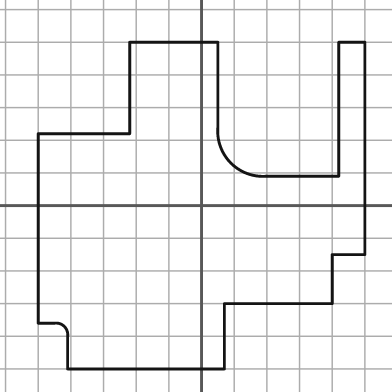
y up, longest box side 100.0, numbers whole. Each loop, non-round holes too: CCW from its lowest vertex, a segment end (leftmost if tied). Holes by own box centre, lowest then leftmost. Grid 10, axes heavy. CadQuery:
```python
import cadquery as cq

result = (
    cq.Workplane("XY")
    .moveTo(-41.0, -50.0)
    .lineTo(7.0, -50.0)
    .lineTo(7.0, -30.0)
    .lineTo(40.0, -30.0)
    .lineTo(40.0, -15.0)
    .lineTo(50.0, -15.0)
    .lineTo(50.0, 50.0)
    .lineTo(42.0, 50.0)
    .lineTo(42.0, 9.0)
    .lineTo(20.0, 9.0)
    .threePointArc((9.0, 13.0), (5.0, 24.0))
    .lineTo(5.0, 50.0)
    .lineTo(-22.0, 50.0)
    .lineTo(-22.0, 22.0)
    .lineTo(-50.0, 22.0)
    .lineTo(-50.0, -36.0)
    .lineTo(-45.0, -36.0)
    .threePointArc((-42.0, -37.0), (-41.0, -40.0))
    .close()
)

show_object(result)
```